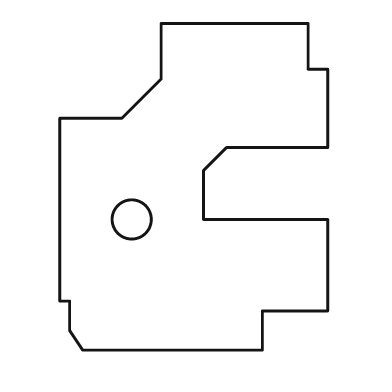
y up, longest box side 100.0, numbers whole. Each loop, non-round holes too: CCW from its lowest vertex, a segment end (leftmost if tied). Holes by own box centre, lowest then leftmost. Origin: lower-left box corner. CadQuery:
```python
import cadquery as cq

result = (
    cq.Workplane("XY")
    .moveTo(7.0, 0.0)
    .lineTo(62.0, 0.0)
    .lineTo(62.0, 12.0)
    .lineTo(82.0, 12.0)
    .lineTo(82.0, 40.0)
    .lineTo(44.0, 40.0)
    .lineTo(44.0, 55.0)
    .lineTo(51.0, 62.0)
    .lineTo(82.0, 62.0)
    .lineTo(82.0, 86.0)
    .lineTo(76.0, 86.0)
    .lineTo(76.0, 100.0)
    .lineTo(31.0, 100.0)
    .lineTo(31.0, 83.0)
    .lineTo(19.0, 71.0)
    .lineTo(0.0, 71.0)
    .lineTo(0.0, 15.0)
    .lineTo(3.0, 15.0)
    .lineTo(3.0, 6.0)
    .close()
    .moveTo(22.0, 40.0)
    .circle(6.0)
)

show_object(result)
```